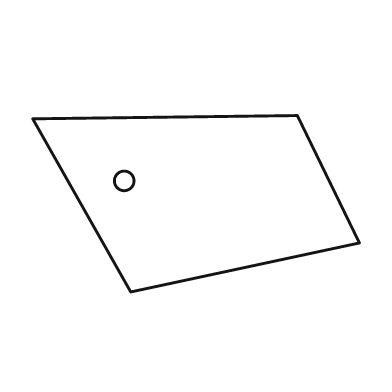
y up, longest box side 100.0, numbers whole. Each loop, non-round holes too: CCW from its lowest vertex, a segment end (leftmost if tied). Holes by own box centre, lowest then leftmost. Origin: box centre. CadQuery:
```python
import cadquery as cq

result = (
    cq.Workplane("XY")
    .moveTo(-20.0, -27.0)
    .lineTo(50.0, -12.0)
    .lineTo(31.0, 27.0)
    .lineTo(-50.0, 26.0)
    .close()
    .moveTo(-22.0, 7.0)
    .circle(3.0)
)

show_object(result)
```